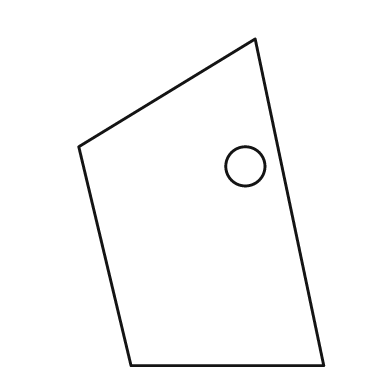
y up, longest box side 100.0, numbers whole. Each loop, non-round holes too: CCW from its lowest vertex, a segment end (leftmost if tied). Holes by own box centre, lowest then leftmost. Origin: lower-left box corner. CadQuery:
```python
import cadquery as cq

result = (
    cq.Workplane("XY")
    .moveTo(16.0, 0.0)
    .lineTo(75.0, 0.0)
    .lineTo(54.0, 100.0)
    .lineTo(0.0, 67.0)
    .close()
    .moveTo(51.0, 61.0)
    .circle(6.0)
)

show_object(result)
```